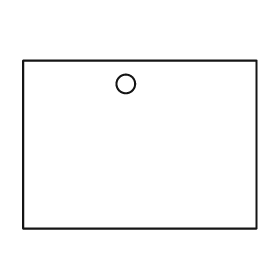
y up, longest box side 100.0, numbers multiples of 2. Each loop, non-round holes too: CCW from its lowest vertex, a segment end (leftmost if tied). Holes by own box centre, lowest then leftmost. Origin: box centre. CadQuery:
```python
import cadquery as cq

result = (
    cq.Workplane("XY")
    .moveTo(-50.0, -36.0)
    .lineTo(50.0, -36.0)
    .lineTo(50.0, 36.0)
    .lineTo(-50.0, 36.0)
    .close()
    .moveTo(-6.0, 26.0)
    .circle(4.0)
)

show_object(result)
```